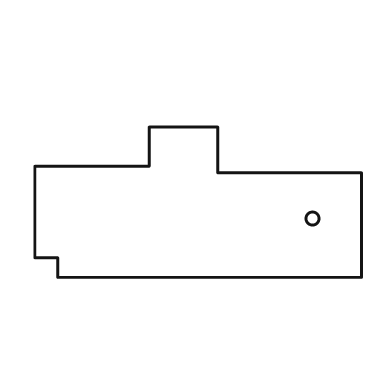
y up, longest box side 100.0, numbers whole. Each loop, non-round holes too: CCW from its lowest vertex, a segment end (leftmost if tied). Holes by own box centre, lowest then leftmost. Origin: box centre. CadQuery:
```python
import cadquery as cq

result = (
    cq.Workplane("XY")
    .moveTo(-43.0, -23.0)
    .lineTo(50.0, -23.0)
    .lineTo(50.0, 9.0)
    .lineTo(6.0, 9.0)
    .lineTo(6.0, 23.0)
    .lineTo(-15.0, 23.0)
    .lineTo(-15.0, 11.0)
    .lineTo(-50.0, 11.0)
    .lineTo(-50.0, -17.0)
    .lineTo(-43.0, -17.0)
    .close()
    .moveTo(35.0, -5.0)
    .circle(2.0)
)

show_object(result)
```